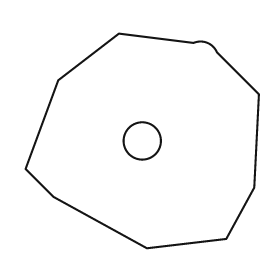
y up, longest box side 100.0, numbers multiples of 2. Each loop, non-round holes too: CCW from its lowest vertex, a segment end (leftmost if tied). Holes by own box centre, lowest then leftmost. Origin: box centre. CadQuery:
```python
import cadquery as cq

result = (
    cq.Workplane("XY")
    .moveTo(2.0, -46.0)
    .lineTo(36.0, -42.0)
    .lineTo(48.0, -20.0)
    .lineTo(50.0, 20.0)
    .lineTo(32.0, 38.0)
    .threePointArc((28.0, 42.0), (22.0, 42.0))
    .lineTo(-10.0, 46.0)
    .lineTo(-36.0, 26.0)
    .lineTo(-50.0, -12.0)
    .lineTo(-38.0, -24.0)
    .close()
    .moveTo(0.0, 0.0)
    .circle(8.0)
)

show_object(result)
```